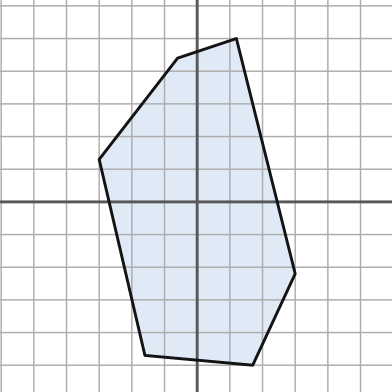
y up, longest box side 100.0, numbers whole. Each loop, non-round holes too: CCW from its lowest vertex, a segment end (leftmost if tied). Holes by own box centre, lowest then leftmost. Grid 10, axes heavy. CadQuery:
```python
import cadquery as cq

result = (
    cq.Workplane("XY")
    .moveTo(17.0, -50.0)
    .lineTo(30.0, -22.0)
    .lineTo(12.0, 50.0)
    .lineTo(-6.0, 44.0)
    .lineTo(-30.0, 13.0)
    .lineTo(-16.0, -47.0)
    .close()
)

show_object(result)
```